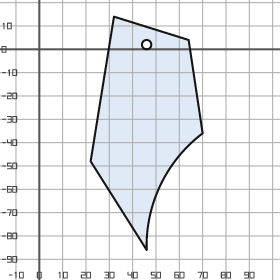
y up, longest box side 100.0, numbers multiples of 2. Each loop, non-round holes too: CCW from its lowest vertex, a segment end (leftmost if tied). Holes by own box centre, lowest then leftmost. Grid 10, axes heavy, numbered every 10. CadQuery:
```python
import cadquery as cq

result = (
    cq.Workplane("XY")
    .moveTo(46.0, -86.0)
    .threePointArc((52.0, -58.0), (70.0, -36.0))
    .lineTo(64.0, 4.0)
    .lineTo(32.0, 14.0)
    .lineTo(22.0, -48.0)
    .close()
    .moveTo(46.0, 2.0)
    .circle(2.0)
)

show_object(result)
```